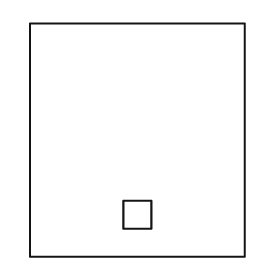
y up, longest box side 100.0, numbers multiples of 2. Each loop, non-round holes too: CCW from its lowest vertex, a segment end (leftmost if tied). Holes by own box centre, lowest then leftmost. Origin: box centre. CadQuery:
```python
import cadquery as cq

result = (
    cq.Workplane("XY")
    .moveTo(-46.0, -50.0)
    .lineTo(46.0, -50.0)
    .lineTo(46.0, 50.0)
    .lineTo(-46.0, 50.0)
    .close()
    .moveTo(-6.0, -38.0)
    .lineTo(6.0, -38.0)
    .lineTo(6.0, -26.0)
    .lineTo(-6.0, -26.0)
    .close()
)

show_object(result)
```